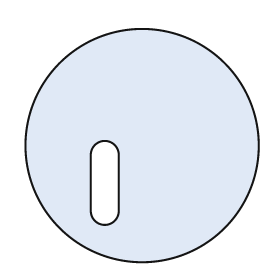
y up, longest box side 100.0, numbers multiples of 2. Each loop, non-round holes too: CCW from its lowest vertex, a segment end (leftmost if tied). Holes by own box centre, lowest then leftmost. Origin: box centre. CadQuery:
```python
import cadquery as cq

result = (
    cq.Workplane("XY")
    .moveTo(0.0, 0.0)
    .circle(50.0)
    .moveTo(-22.0, -28.0)
    .threePointArc((-16.0, -34.0), (-10.0, -28.0))
    .lineTo(-10.0, -4.0)
    .threePointArc((-16.0, 2.0), (-22.0, -4.0))
    .close()
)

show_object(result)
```